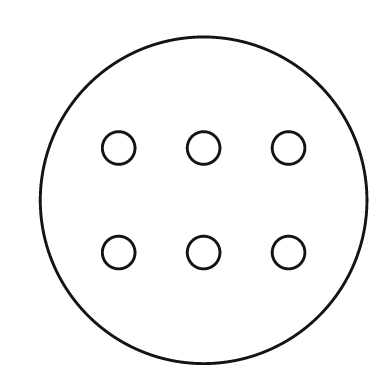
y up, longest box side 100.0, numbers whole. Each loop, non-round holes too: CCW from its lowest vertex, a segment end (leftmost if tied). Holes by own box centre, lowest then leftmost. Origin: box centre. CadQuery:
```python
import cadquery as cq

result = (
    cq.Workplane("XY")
    .moveTo(0.0, 0.0)
    .circle(50.0)
    .moveTo(-26.0, -16.0)
    .circle(5.0)
    .moveTo(0.0, -16.0)
    .circle(5.0)
    .moveTo(26.0, -16.0)
    .circle(5.0)
    .moveTo(-26.0, 16.0)
    .circle(5.0)
    .moveTo(0.0, 16.0)
    .circle(5.0)
    .moveTo(26.0, 16.0)
    .circle(5.0)
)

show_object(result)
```